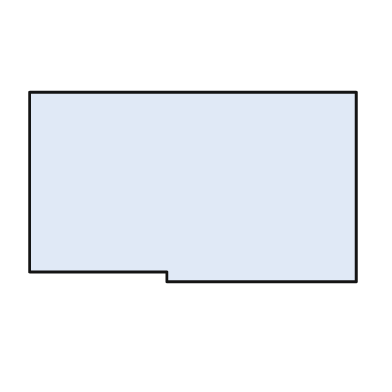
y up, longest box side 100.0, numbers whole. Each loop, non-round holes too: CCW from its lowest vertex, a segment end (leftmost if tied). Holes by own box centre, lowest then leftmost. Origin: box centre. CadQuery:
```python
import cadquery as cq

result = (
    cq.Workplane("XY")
    .moveTo(-8.0, -29.0)
    .lineTo(50.0, -29.0)
    .lineTo(50.0, 29.0)
    .lineTo(-50.0, 29.0)
    .lineTo(-50.0, -26.0)
    .lineTo(-8.0, -26.0)
    .close()
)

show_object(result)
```